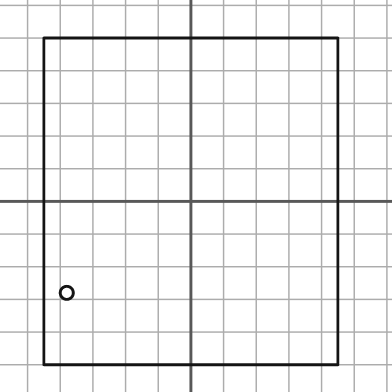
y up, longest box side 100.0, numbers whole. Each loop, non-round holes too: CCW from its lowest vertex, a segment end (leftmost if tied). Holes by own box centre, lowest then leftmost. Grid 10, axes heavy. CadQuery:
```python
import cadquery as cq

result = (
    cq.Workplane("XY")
    .moveTo(-45.0, -50.0)
    .lineTo(45.0, -50.0)
    .lineTo(45.0, 50.0)
    .lineTo(-45.0, 50.0)
    .close()
    .moveTo(-38.0, -28.0)
    .circle(2.0)
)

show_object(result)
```